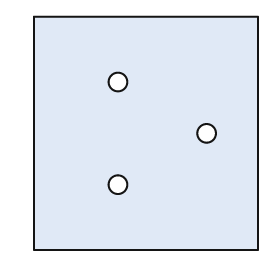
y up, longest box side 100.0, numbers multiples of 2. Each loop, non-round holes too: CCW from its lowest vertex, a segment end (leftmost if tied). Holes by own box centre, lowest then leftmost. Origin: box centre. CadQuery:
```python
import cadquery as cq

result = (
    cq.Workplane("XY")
    .moveTo(-48.0, -50.0)
    .lineTo(48.0, -50.0)
    .lineTo(48.0, 50.0)
    .lineTo(-48.0, 50.0)
    .close()
    .moveTo(-12.0, -22.0)
    .circle(4.0)
    .moveTo(26.0, 0.0)
    .circle(4.0)
    .moveTo(-12.0, 22.0)
    .circle(4.0)
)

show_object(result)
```